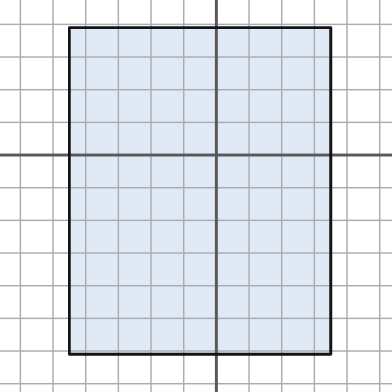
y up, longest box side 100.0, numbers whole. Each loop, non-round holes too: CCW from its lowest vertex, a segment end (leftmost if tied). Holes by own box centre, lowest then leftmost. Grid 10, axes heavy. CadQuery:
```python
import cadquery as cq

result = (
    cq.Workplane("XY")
    .moveTo(-45.0, -61.0)
    .lineTo(35.0, -61.0)
    .lineTo(35.0, 39.0)
    .lineTo(-45.0, 39.0)
    .close()
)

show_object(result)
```